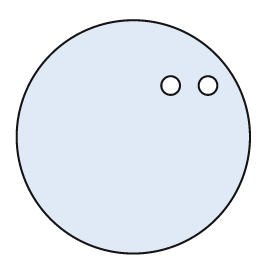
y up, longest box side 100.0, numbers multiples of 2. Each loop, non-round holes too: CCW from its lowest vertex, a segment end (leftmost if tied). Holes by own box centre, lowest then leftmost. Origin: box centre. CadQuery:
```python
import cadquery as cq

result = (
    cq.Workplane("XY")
    .moveTo(0.0, 0.0)
    .circle(50.0)
    .moveTo(16.0, 22.0)
    .circle(4.0)
    .moveTo(32.0, 22.0)
    .circle(4.0)
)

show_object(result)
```